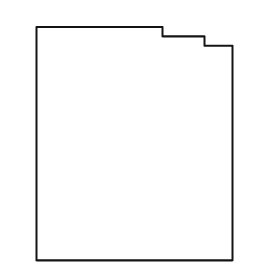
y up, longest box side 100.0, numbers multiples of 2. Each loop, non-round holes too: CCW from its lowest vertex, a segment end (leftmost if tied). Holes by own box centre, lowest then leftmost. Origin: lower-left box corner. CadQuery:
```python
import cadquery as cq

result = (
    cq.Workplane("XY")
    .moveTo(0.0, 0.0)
    .lineTo(84.0, 0.0)
    .lineTo(84.0, 92.0)
    .lineTo(72.0, 92.0)
    .lineTo(72.0, 96.0)
    .lineTo(54.0, 96.0)
    .lineTo(54.0, 100.0)
    .lineTo(0.0, 100.0)
    .close()
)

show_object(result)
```